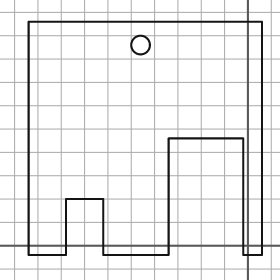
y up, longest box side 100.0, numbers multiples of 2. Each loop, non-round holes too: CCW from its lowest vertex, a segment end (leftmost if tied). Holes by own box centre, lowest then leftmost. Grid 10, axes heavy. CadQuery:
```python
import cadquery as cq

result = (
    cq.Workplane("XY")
    .moveTo(-94.0, -4.0)
    .lineTo(-78.0, -4.0)
    .lineTo(-78.0, 20.0)
    .lineTo(-62.0, 20.0)
    .lineTo(-62.0, -4.0)
    .lineTo(-34.0, -4.0)
    .lineTo(-34.0, 46.0)
    .lineTo(-2.0, 46.0)
    .lineTo(-2.0, -4.0)
    .lineTo(6.0, -4.0)
    .lineTo(6.0, 96.0)
    .lineTo(-94.0, 96.0)
    .close()
    .moveTo(-46.0, 86.0)
    .circle(4.0)
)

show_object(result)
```